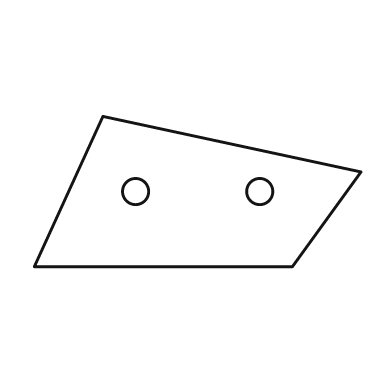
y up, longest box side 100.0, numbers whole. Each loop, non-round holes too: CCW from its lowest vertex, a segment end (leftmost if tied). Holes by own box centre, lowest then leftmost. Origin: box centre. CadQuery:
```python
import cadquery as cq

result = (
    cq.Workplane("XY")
    .moveTo(-50.0, -23.0)
    .lineTo(29.0, -23.0)
    .lineTo(50.0, 6.0)
    .lineTo(-29.0, 23.0)
    .close()
    .moveTo(-19.0, 0.0)
    .circle(4.0)
    .moveTo(19.0, 0.0)
    .circle(4.0)
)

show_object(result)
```